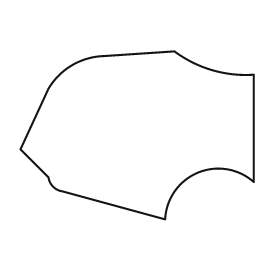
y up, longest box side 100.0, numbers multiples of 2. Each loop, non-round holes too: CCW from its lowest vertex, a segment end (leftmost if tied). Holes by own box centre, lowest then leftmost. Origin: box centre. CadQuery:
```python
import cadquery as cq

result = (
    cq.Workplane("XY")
    .moveTo(12.0, -36.0)
    .threePointArc((26.0, -16.0), (50.0, -20.0))
    .lineTo(50.0, 26.0)
    .threePointArc((32.0, 28.0), (16.0, 36.0))
    .lineTo(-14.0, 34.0)
    .threePointArc((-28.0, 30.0), (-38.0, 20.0))
    .lineTo(-50.0, -6.0)
    .lineTo(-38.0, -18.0)
    .threePointArc((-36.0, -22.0), (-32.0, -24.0))
    .close()
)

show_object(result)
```